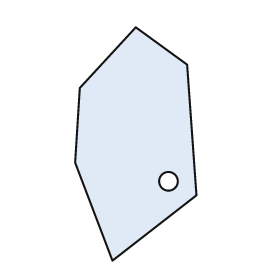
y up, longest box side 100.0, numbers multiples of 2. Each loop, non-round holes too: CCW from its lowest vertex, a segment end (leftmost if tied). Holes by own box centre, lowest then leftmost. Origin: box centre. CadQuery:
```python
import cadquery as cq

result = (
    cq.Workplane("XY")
    .moveTo(-10.0, -50.0)
    .lineTo(26.0, -22.0)
    .lineTo(22.0, 34.0)
    .lineTo(0.0, 50.0)
    .lineTo(-24.0, 24.0)
    .lineTo(-26.0, -8.0)
    .close()
    .moveTo(14.0, -16.0)
    .circle(4.0)
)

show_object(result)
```